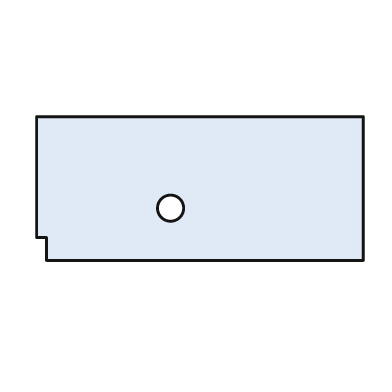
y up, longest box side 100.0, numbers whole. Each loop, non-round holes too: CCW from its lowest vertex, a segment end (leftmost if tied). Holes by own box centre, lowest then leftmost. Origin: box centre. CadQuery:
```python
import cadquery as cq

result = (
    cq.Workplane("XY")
    .moveTo(-47.0, -22.0)
    .lineTo(50.0, -22.0)
    .lineTo(50.0, 22.0)
    .lineTo(-50.0, 22.0)
    .lineTo(-50.0, -15.0)
    .lineTo(-47.0, -15.0)
    .close()
    .moveTo(-9.0, -6.0)
    .circle(4.0)
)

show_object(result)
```